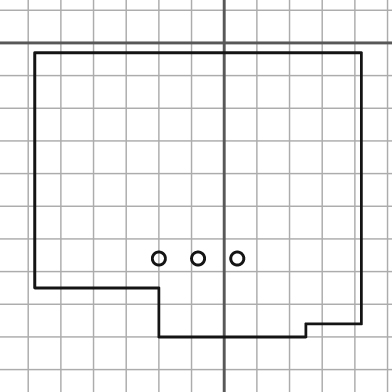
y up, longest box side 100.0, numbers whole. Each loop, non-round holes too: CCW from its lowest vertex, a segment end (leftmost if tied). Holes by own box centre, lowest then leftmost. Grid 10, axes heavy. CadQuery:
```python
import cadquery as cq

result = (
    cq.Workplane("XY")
    .moveTo(-20.0, -90.0)
    .lineTo(25.0, -90.0)
    .lineTo(25.0, -86.0)
    .lineTo(42.0, -86.0)
    .lineTo(42.0, -3.0)
    .lineTo(-58.0, -3.0)
    .lineTo(-58.0, -75.0)
    .lineTo(-20.0, -75.0)
    .close()
    .moveTo(-20.0, -66.0)
    .circle(2.0)
    .moveTo(-8.0, -66.0)
    .circle(2.0)
    .moveTo(4.0, -66.0)
    .circle(2.0)
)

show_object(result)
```